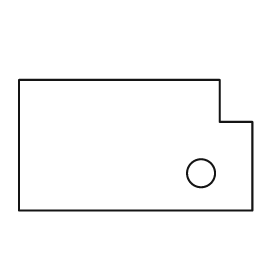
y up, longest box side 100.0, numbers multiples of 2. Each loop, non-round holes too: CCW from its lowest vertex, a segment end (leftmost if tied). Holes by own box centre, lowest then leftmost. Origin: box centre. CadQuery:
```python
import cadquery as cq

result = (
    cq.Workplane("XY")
    .moveTo(-50.0, -28.0)
    .lineTo(50.0, -28.0)
    .lineTo(50.0, 10.0)
    .lineTo(36.0, 10.0)
    .lineTo(36.0, 28.0)
    .lineTo(-50.0, 28.0)
    .close()
    .moveTo(28.0, -12.0)
    .circle(6.0)
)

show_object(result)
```